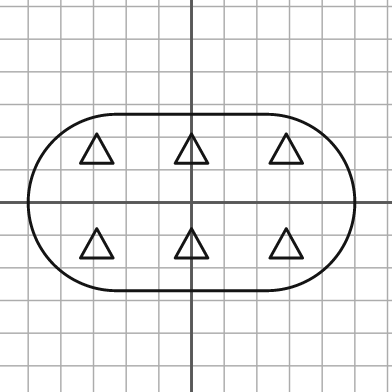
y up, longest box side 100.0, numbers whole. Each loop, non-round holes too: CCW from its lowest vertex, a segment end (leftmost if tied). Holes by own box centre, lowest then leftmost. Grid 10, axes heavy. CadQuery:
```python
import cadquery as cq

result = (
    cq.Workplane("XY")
    .moveTo(-23.0, -27.0)
    .lineTo(23.0, -27.0)
    .threePointArc((50.0, 0.0), (23.0, 27.0))
    .lineTo(-23.0, 27.0)
    .threePointArc((-50.0, 0.0), (-23.0, -27.0))
    .close()
    .moveTo(-34.0, -17.0)
    .lineTo(-24.0, -17.0)
    .lineTo(-29.0, -8.0)
    .close()
    .moveTo(-5.0, -17.0)
    .lineTo(5.0, -17.0)
    .lineTo(0.0, -8.0)
    .close()
    .moveTo(24.0, -17.0)
    .lineTo(34.0, -17.0)
    .lineTo(29.0, -8.0)
    .close()
    .moveTo(-34.0, 12.0)
    .lineTo(-24.0, 12.0)
    .lineTo(-29.0, 21.0)
    .close()
    .moveTo(-5.0, 12.0)
    .lineTo(5.0, 12.0)
    .lineTo(0.0, 21.0)
    .close()
    .moveTo(24.0, 12.0)
    .lineTo(34.0, 12.0)
    .lineTo(29.0, 21.0)
    .close()
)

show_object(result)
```